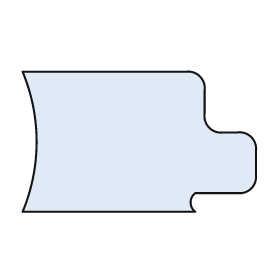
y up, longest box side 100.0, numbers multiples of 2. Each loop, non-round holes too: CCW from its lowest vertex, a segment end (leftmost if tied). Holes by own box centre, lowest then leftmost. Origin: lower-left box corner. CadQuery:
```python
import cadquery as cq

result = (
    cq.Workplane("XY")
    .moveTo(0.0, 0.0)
    .lineTo(74.0, 0.0)
    .threePointArc((72.0, 4.0), (74.0, 8.0))
    .lineTo(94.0, 8.0)
    .threePointArc((98.0, 10.0), (100.0, 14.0))
    .lineTo(100.0, 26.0)
    .threePointArc((98.0, 32.0), (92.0, 34.0))
    .lineTo(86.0, 34.0)
    .threePointArc((80.0, 36.0), (78.0, 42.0))
    .lineTo(78.0, 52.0)
    .threePointArc((76.0, 58.0), (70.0, 60.0))
    .lineTo(0.0, 60.0)
    .threePointArc((6.0, 30.0), (0.0, 0.0))
    .close()
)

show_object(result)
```